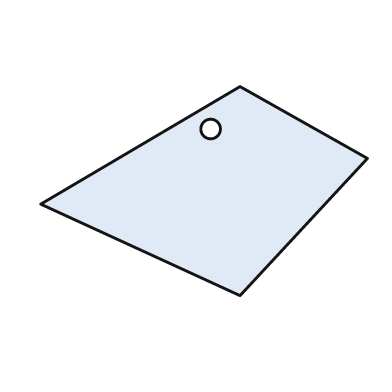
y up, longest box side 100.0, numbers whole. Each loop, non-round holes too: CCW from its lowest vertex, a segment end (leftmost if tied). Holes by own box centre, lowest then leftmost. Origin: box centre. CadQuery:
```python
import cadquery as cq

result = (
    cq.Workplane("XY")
    .moveTo(11.0, -32.0)
    .lineTo(50.0, 10.0)
    .lineTo(11.0, 32.0)
    .lineTo(-50.0, -4.0)
    .close()
    .moveTo(2.0, 19.0)
    .circle(3.0)
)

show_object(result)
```